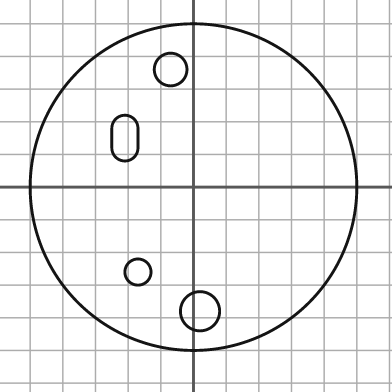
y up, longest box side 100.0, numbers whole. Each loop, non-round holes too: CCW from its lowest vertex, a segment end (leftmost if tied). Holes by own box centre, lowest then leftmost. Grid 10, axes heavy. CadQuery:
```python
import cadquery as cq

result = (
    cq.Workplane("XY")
    .moveTo(0.0, 0.0)
    .circle(50.0)
    .moveTo(2.0, -38.0)
    .circle(6.0)
    .moveTo(-17.0, -26.0)
    .circle(4.0)
    .moveTo(-25.0, 12.0)
    .threePointArc((-21.0, 8.0), (-17.0, 12.0))
    .lineTo(-17.0, 18.0)
    .threePointArc((-21.0, 22.0), (-25.0, 18.0))
    .close()
    .moveTo(-7.0, 36.0)
    .circle(5.0)
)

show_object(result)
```